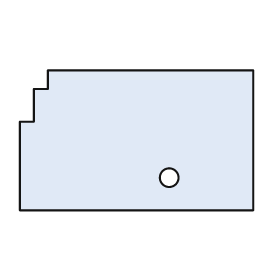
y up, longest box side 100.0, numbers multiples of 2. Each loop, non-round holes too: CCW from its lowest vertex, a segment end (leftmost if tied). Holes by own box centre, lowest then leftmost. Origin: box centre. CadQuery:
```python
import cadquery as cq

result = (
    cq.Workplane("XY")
    .moveTo(-50.0, -30.0)
    .lineTo(50.0, -30.0)
    .lineTo(50.0, 30.0)
    .lineTo(-38.0, 30.0)
    .lineTo(-38.0, 22.0)
    .lineTo(-44.0, 22.0)
    .lineTo(-44.0, 8.0)
    .lineTo(-50.0, 8.0)
    .close()
    .moveTo(14.0, -16.0)
    .circle(4.0)
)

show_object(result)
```